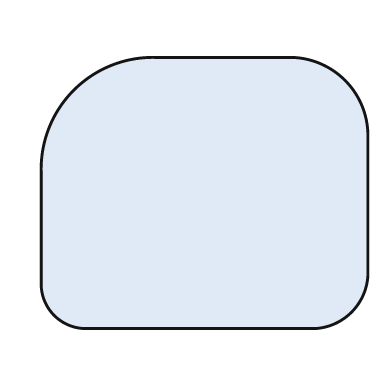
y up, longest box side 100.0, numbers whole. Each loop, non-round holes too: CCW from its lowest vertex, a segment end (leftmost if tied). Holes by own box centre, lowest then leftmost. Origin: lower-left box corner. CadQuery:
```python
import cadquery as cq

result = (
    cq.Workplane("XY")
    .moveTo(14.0, 0.0)
    .lineTo(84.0, 0.0)
    .threePointArc((95.0, 5.0), (100.0, 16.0))
    .lineTo(100.0, 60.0)
    .threePointArc((93.0, 76.0), (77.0, 83.0))
    .lineTo(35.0, 83.0)
    .threePointArc((10.0, 73.0), (0.0, 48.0))
    .lineTo(0.0, 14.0)
    .threePointArc((4.0, 4.0), (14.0, 0.0))
    .close()
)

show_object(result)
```